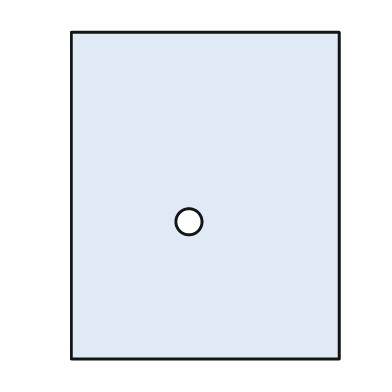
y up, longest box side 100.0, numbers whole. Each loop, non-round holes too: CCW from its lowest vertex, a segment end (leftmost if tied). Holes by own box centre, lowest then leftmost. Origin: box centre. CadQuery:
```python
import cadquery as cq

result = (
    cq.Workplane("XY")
    .moveTo(-41.0, -50.0)
    .lineTo(41.0, -50.0)
    .lineTo(41.0, 50.0)
    .lineTo(-41.0, 50.0)
    .close()
    .moveTo(-5.0, -8.0)
    .circle(4.0)
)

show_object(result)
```